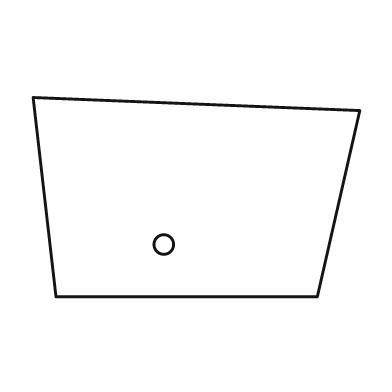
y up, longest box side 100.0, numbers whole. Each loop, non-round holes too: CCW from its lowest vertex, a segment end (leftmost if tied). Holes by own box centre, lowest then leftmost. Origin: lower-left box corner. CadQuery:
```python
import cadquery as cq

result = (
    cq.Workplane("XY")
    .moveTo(7.0, 0.0)
    .lineTo(87.0, 0.0)
    .lineTo(100.0, 57.0)
    .lineTo(0.0, 61.0)
    .close()
    .moveTo(40.0, 16.0)
    .circle(3.0)
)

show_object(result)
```